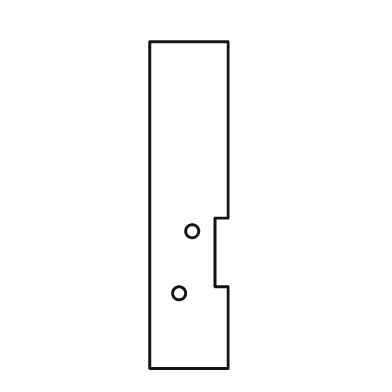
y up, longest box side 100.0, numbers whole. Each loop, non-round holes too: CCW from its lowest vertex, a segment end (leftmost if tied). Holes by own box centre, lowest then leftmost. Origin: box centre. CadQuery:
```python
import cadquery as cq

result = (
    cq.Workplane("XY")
    .moveTo(-12.0, -50.0)
    .lineTo(12.0, -50.0)
    .lineTo(12.0, -25.0)
    .lineTo(8.0, -25.0)
    .lineTo(8.0, -4.0)
    .lineTo(12.0, -4.0)
    .lineTo(12.0, 50.0)
    .lineTo(-12.0, 50.0)
    .close()
    .moveTo(-3.0, -27.0)
    .circle(2.0)
    .moveTo(1.0, -8.0)
    .circle(2.0)
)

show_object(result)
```